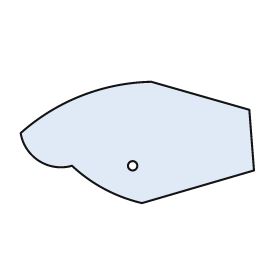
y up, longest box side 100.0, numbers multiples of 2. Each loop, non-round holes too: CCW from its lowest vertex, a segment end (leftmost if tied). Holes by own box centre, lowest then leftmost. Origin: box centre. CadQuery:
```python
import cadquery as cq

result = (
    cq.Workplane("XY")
    .moveTo(2.0, -26.0)
    .lineTo(50.0, -12.0)
    .lineTo(48.0, 14.0)
    .lineTo(6.0, 26.0)
    .threePointArc((-24.0, 20.0), (-50.0, 4.0))
    .threePointArc((-42.0, -8.0), (-28.0, -10.0))
    .threePointArc((-14.0, -20.0), (2.0, -26.0))
    .close()
    .moveTo(-2.0, -10.0)
    .circle(2.0)
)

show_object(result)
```